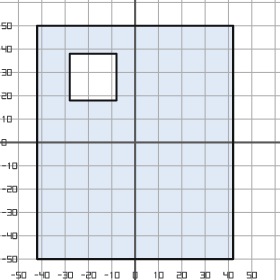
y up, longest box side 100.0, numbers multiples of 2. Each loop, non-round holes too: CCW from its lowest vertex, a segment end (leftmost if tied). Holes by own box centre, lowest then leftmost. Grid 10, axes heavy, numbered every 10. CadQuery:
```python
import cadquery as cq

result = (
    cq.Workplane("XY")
    .moveTo(-42.0, -50.0)
    .lineTo(42.0, -50.0)
    .lineTo(42.0, 50.0)
    .lineTo(-42.0, 50.0)
    .close()
    .moveTo(-28.0, 18.0)
    .lineTo(-8.0, 18.0)
    .lineTo(-8.0, 38.0)
    .lineTo(-28.0, 38.0)
    .close()
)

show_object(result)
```